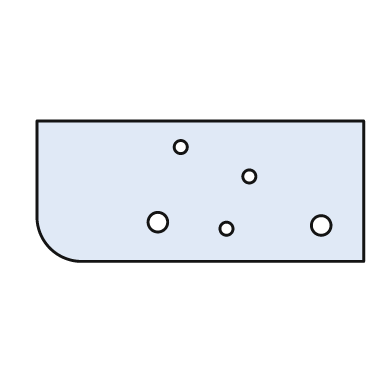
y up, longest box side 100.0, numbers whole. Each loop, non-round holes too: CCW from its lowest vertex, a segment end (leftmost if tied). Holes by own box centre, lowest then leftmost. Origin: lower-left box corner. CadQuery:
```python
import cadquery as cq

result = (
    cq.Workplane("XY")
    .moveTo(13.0, 0.0)
    .lineTo(100.0, 0.0)
    .lineTo(100.0, 43.0)
    .lineTo(0.0, 43.0)
    .lineTo(0.0, 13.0)
    .threePointArc((4.0, 4.0), (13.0, 0.0))
    .close()
    .moveTo(58.0, 10.0)
    .circle(2.0)
    .moveTo(87.0, 11.0)
    .circle(3.0)
    .moveTo(37.0, 12.0)
    .circle(3.0)
    .moveTo(65.0, 26.0)
    .circle(2.0)
    .moveTo(44.0, 35.0)
    .circle(2.0)
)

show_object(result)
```